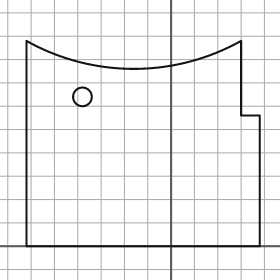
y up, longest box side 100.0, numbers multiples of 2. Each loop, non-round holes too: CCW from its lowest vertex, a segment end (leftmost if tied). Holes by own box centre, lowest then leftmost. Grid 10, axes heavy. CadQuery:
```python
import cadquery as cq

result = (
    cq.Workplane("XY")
    .moveTo(-62.0, 0.0)
    .lineTo(38.0, 0.0)
    .lineTo(38.0, 56.0)
    .lineTo(30.0, 56.0)
    .lineTo(30.0, 88.0)
    .threePointArc((-16.0, 76.0), (-62.0, 88.0))
    .close()
    .moveTo(-38.0, 64.0)
    .circle(4.0)
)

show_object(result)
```